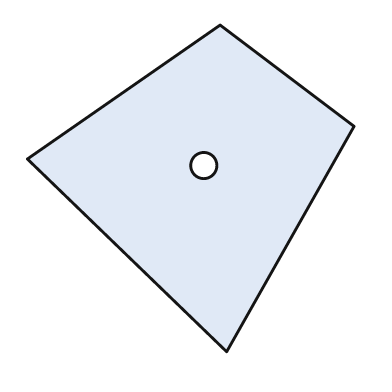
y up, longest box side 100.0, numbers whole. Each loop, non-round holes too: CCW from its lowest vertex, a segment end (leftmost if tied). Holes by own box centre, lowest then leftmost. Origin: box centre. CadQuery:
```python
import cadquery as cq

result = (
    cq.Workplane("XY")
    .moveTo(11.0, -50.0)
    .lineTo(50.0, 19.0)
    .lineTo(9.0, 50.0)
    .lineTo(-50.0, 9.0)
    .close()
    .moveTo(4.0, 7.0)
    .circle(4.0)
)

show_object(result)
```